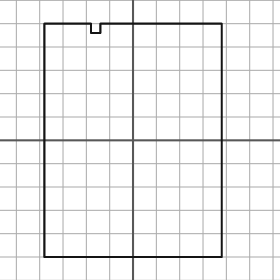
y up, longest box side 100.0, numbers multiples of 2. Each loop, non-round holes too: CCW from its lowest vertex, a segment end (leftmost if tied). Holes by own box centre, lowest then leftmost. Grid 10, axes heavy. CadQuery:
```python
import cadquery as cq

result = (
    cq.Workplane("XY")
    .moveTo(-38.0, -50.0)
    .lineTo(38.0, -50.0)
    .lineTo(38.0, 50.0)
    .lineTo(-14.0, 50.0)
    .lineTo(-14.0, 46.0)
    .lineTo(-18.0, 46.0)
    .lineTo(-18.0, 50.0)
    .lineTo(-38.0, 50.0)
    .close()
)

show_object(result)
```